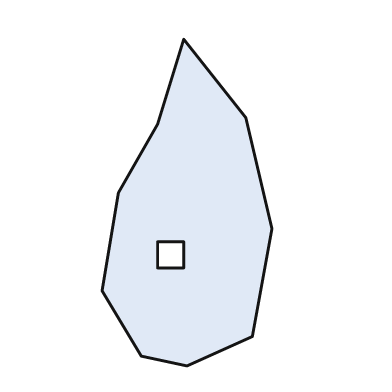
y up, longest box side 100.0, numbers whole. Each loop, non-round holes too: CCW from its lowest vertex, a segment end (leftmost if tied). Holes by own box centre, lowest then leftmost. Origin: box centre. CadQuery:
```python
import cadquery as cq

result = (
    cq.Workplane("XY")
    .moveTo(0.0, -50.0)
    .lineTo(20.0, -41.0)
    .lineTo(26.0, -8.0)
    .lineTo(18.0, 26.0)
    .lineTo(-1.0, 50.0)
    .lineTo(-9.0, 24.0)
    .lineTo(-21.0, 3.0)
    .lineTo(-26.0, -27.0)
    .lineTo(-14.0, -47.0)
    .close()
    .moveTo(-9.0, -20.0)
    .lineTo(-1.0, -20.0)
    .lineTo(-1.0, -12.0)
    .lineTo(-9.0, -12.0)
    .close()
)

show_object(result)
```